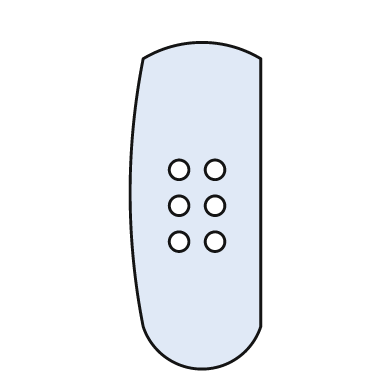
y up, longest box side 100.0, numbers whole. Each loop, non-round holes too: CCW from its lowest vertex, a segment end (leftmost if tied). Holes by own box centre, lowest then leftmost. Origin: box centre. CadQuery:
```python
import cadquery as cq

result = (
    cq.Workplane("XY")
    .moveTo(-16.0, -37.0)
    .threePointArc((2.0, -50.0), (20.0, -37.0))
    .lineTo(20.0, 45.0)
    .threePointArc((2.0, 50.0), (-16.0, 45.0))
    .threePointArc((-20.0, 4.0), (-16.0, -37.0))
    .close()
    .moveTo(-5.0, -11.0)
    .circle(3.0)
    .moveTo(6.0, -11.0)
    .circle(3.0)
    .moveTo(-5.0, 0.0)
    .circle(3.0)
    .moveTo(6.0, 0.0)
    .circle(3.0)
    .moveTo(-5.0, 11.0)
    .circle(3.0)
    .moveTo(6.0, 11.0)
    .circle(3.0)
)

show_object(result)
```